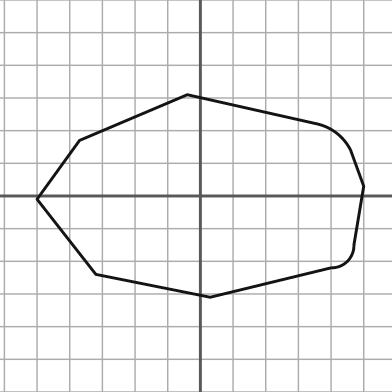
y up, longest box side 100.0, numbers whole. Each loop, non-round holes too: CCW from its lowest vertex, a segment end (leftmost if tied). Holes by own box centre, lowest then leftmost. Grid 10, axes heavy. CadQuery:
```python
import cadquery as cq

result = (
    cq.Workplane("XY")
    .moveTo(3.0, -31.0)
    .lineTo(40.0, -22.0)
    .threePointArc((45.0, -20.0), (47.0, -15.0))
    .lineTo(50.0, 3.0)
    .lineTo(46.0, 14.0)
    .threePointArc((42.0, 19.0), (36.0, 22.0))
    .lineTo(-4.0, 31.0)
    .lineTo(-37.0, 17.0)
    .lineTo(-50.0, -1.0)
    .lineTo(-32.0, -24.0)
    .close()
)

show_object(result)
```